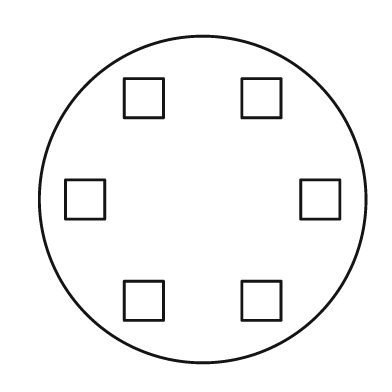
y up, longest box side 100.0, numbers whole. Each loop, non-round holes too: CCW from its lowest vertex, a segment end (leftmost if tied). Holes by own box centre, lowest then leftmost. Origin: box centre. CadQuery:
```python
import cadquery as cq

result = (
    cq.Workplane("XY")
    .moveTo(0.0, 0.0)
    .circle(50.0)
    .moveTo(-24.0, -37.0)
    .lineTo(-12.0, -37.0)
    .lineTo(-12.0, -25.0)
    .lineTo(-24.0, -25.0)
    .close()
    .moveTo(12.0, -37.0)
    .lineTo(24.0, -37.0)
    .lineTo(24.0, -25.0)
    .lineTo(12.0, -25.0)
    .close()
    .moveTo(-42.0, -6.0)
    .lineTo(-30.0, -6.0)
    .lineTo(-30.0, 6.0)
    .lineTo(-42.0, 6.0)
    .close()
    .moveTo(30.0, -6.0)
    .lineTo(42.0, -6.0)
    .lineTo(42.0, 6.0)
    .lineTo(30.0, 6.0)
    .close()
    .moveTo(-24.0, 25.0)
    .lineTo(-12.0, 25.0)
    .lineTo(-12.0, 37.0)
    .lineTo(-24.0, 37.0)
    .close()
    .moveTo(12.0, 25.0)
    .lineTo(24.0, 25.0)
    .lineTo(24.0, 37.0)
    .lineTo(12.0, 37.0)
    .close()
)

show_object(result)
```